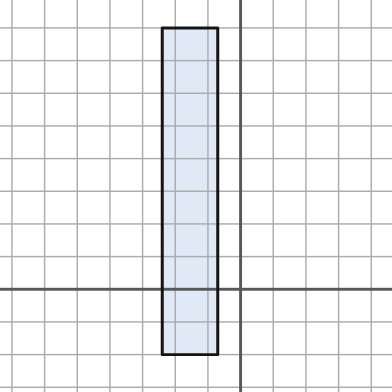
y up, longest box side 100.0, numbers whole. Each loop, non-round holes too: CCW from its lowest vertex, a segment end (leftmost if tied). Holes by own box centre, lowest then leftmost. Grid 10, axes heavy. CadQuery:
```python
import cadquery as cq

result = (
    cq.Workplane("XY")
    .moveTo(-24.0, -20.0)
    .lineTo(-7.0, -20.0)
    .lineTo(-7.0, 80.0)
    .lineTo(-24.0, 80.0)
    .close()
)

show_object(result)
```